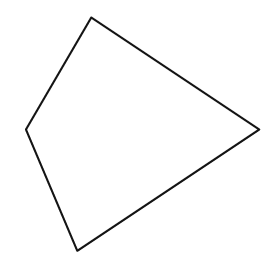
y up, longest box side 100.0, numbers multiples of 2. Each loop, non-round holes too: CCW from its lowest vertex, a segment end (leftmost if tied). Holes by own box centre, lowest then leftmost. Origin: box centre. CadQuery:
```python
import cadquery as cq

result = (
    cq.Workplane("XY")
    .moveTo(-28.0, -50.0)
    .lineTo(50.0, 2.0)
    .lineTo(-22.0, 50.0)
    .lineTo(-50.0, 2.0)
    .close()
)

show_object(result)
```